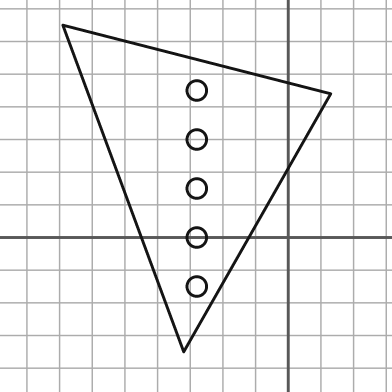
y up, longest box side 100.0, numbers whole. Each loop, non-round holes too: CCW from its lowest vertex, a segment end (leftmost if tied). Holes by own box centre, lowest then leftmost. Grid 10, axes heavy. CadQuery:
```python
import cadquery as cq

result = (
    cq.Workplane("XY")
    .moveTo(-32.0, -35.0)
    .lineTo(13.0, 44.0)
    .lineTo(-69.0, 65.0)
    .close()
    .moveTo(-28.0, -15.0)
    .circle(3.0)
    .moveTo(-28.0, 0.0)
    .circle(3.0)
    .moveTo(-28.0, 15.0)
    .circle(3.0)
    .moveTo(-28.0, 30.0)
    .circle(3.0)
    .moveTo(-28.0, 45.0)
    .circle(3.0)
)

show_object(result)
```